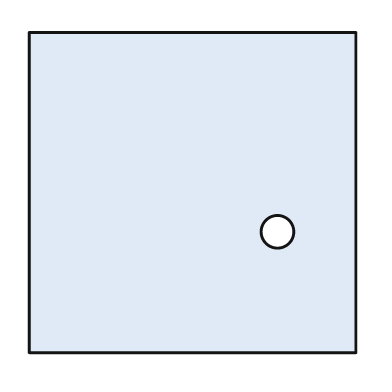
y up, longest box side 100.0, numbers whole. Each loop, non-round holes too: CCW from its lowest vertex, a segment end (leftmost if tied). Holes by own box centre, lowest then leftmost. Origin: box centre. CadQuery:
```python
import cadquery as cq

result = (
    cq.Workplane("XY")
    .moveTo(-50.0, -49.0)
    .lineTo(50.0, -49.0)
    .lineTo(50.0, 49.0)
    .lineTo(-50.0, 49.0)
    .close()
    .moveTo(26.0, -12.0)
    .circle(5.0)
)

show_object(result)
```